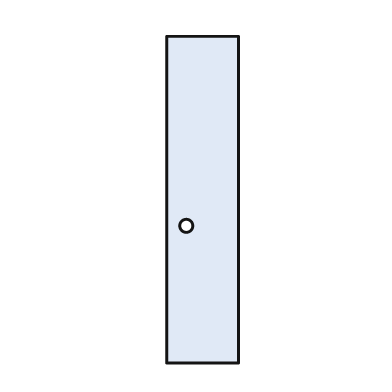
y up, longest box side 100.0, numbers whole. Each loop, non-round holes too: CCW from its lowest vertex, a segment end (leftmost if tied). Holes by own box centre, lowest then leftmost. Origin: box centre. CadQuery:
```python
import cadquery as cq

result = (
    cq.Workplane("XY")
    .moveTo(-11.0, -50.0)
    .lineTo(11.0, -50.0)
    .lineTo(11.0, 50.0)
    .lineTo(-11.0, 50.0)
    .close()
    .moveTo(-5.0, -8.0)
    .circle(2.0)
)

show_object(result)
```